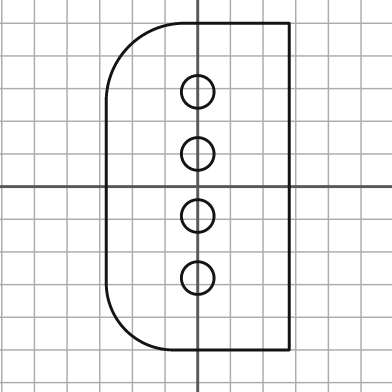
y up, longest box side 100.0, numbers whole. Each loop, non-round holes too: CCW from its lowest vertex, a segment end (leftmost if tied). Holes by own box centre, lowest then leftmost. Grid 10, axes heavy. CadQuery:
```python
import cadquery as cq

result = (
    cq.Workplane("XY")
    .moveTo(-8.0, -50.0)
    .lineTo(28.0, -50.0)
    .lineTo(28.0, 50.0)
    .lineTo(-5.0, 50.0)
    .threePointArc((-21.0, 43.0), (-28.0, 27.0))
    .lineTo(-28.0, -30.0)
    .threePointArc((-22.0, -44.0), (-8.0, -50.0))
    .close()
    .moveTo(0.0, -28.0)
    .circle(5.0)
    .moveTo(0.0, -9.0)
    .circle(5.0)
    .moveTo(0.0, 10.0)
    .circle(5.0)
    .moveTo(0.0, 29.0)
    .circle(5.0)
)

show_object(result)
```